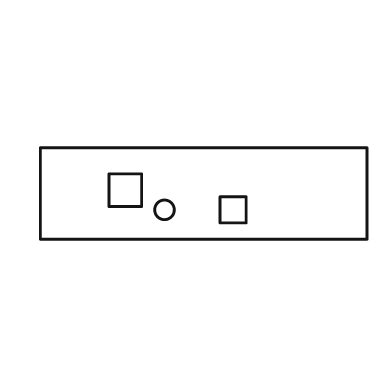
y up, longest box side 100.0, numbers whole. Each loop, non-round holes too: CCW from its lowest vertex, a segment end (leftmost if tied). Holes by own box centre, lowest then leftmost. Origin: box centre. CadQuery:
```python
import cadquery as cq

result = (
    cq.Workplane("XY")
    .moveTo(-50.0, -14.0)
    .lineTo(50.0, -14.0)
    .lineTo(50.0, 14.0)
    .lineTo(-50.0, 14.0)
    .close()
    .moveTo(-12.0, -5.0)
    .circle(3.0)
    .moveTo(5.0, -9.0)
    .lineTo(13.0, -9.0)
    .lineTo(13.0, -1.0)
    .lineTo(5.0, -1.0)
    .close()
    .moveTo(-29.0, -4.0)
    .lineTo(-19.0, -4.0)
    .lineTo(-19.0, 6.0)
    .lineTo(-29.0, 6.0)
    .close()
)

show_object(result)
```